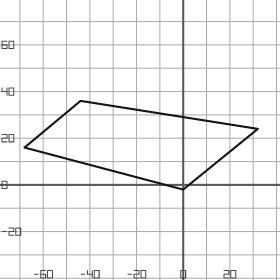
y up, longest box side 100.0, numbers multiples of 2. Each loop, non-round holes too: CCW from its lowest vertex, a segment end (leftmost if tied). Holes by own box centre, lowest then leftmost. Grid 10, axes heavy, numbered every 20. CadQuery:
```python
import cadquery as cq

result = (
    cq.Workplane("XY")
    .moveTo(0.0, -2.0)
    .lineTo(32.0, 24.0)
    .lineTo(-44.0, 36.0)
    .lineTo(-68.0, 16.0)
    .close()
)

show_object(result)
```